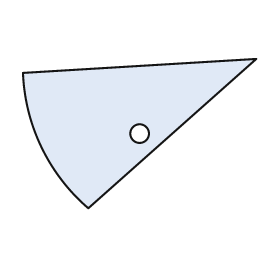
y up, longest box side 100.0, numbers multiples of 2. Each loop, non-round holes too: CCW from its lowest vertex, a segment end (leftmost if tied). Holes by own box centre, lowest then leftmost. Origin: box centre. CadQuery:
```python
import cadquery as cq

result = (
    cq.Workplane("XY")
    .moveTo(-22.0, -32.0)
    .lineTo(50.0, 32.0)
    .lineTo(-50.0, 26.0)
    .threePointArc((-42.0, -6.0), (-22.0, -32.0))
    .close()
    .moveTo(0.0, 0.0)
    .circle(4.0)
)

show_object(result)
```